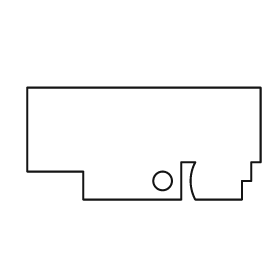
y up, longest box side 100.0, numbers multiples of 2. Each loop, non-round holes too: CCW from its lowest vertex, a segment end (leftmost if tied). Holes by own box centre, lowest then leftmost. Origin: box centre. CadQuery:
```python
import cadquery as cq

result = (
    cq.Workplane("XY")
    .moveTo(-26.0, -24.0)
    .lineTo(16.0, -24.0)
    .lineTo(16.0, -8.0)
    .lineTo(22.0, -8.0)
    .threePointArc((20.0, -16.0), (22.0, -24.0))
    .lineTo(42.0, -24.0)
    .lineTo(42.0, -16.0)
    .lineTo(46.0, -16.0)
    .lineTo(46.0, -8.0)
    .lineTo(50.0, -8.0)
    .lineTo(50.0, 24.0)
    .lineTo(-50.0, 24.0)
    .lineTo(-50.0, -12.0)
    .lineTo(-26.0, -12.0)
    .close()
    .moveTo(8.0, -16.0)
    .circle(4.0)
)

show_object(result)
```